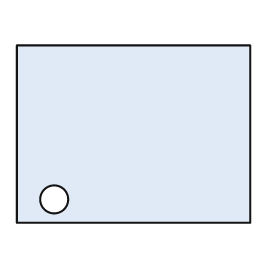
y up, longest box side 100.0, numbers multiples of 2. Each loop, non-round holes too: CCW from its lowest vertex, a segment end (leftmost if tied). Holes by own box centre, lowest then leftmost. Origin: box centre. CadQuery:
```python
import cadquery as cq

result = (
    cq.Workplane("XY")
    .moveTo(-50.0, -38.0)
    .lineTo(50.0, -38.0)
    .lineTo(50.0, 38.0)
    .lineTo(-50.0, 38.0)
    .close()
    .moveTo(-34.0, -28.0)
    .circle(6.0)
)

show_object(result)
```